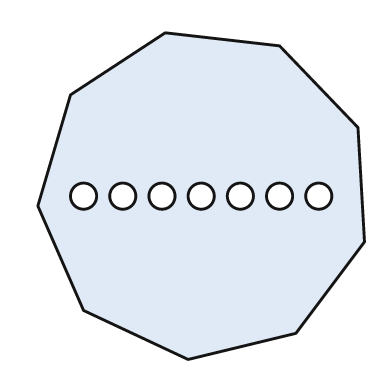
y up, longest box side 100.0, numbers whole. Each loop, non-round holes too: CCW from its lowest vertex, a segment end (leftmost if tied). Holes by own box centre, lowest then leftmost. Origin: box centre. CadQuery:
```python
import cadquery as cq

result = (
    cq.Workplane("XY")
    .moveTo(-4.0, -50.0)
    .lineTo(29.0, -42.0)
    .lineTo(50.0, -14.0)
    .lineTo(48.0, 21.0)
    .lineTo(24.0, 46.0)
    .lineTo(-11.0, 50.0)
    .lineTo(-40.0, 31.0)
    .lineTo(-50.0, -3.0)
    .lineTo(-36.0, -35.0)
    .close()
    .moveTo(-36.0, 0.0)
    .circle(4.0)
    .moveTo(-24.0, 0.0)
    .circle(4.0)
    .moveTo(-12.0, 0.0)
    .circle(4.0)
    .moveTo(0.0, 0.0)
    .circle(4.0)
    .moveTo(12.0, 0.0)
    .circle(4.0)
    .moveTo(24.0, 0.0)
    .circle(4.0)
    .moveTo(36.0, 0.0)
    .circle(4.0)
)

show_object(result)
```